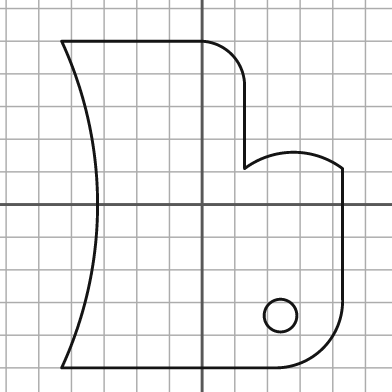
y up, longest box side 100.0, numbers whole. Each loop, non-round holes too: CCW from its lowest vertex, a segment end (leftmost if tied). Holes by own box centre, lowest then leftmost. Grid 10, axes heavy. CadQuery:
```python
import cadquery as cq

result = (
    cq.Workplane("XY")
    .moveTo(-43.0, -50.0)
    .lineTo(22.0, -50.0)
    .threePointArc((37.0, -44.0), (43.0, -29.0))
    .lineTo(43.0, 11.0)
    .threePointArc((28.0, 16.0), (13.0, 11.0))
    .lineTo(13.0, 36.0)
    .threePointArc((9.0, 46.0), (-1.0, 50.0))
    .lineTo(-43.0, 50.0)
    .threePointArc((-32.0, 0.0), (-43.0, -50.0))
    .close()
    .moveTo(24.0, -34.0)
    .circle(5.0)
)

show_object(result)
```